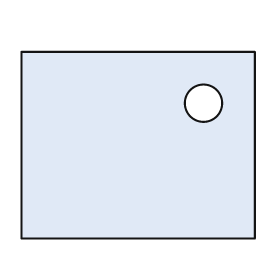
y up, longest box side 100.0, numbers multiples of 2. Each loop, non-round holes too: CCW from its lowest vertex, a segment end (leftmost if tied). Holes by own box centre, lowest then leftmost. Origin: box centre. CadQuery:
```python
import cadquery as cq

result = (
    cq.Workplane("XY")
    .moveTo(-50.0, -40.0)
    .lineTo(50.0, -40.0)
    .lineTo(50.0, 40.0)
    .lineTo(-50.0, 40.0)
    .close()
    .moveTo(28.0, 18.0)
    .circle(8.0)
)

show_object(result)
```